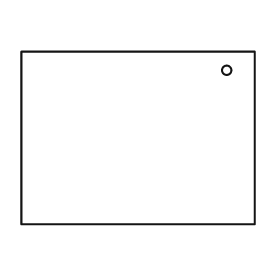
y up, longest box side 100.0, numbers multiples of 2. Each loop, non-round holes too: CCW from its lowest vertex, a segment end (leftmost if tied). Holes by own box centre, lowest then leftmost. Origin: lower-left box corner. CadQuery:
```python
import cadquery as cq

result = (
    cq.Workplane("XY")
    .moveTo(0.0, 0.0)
    .lineTo(100.0, 0.0)
    .lineTo(100.0, 74.0)
    .lineTo(0.0, 74.0)
    .close()
    .moveTo(88.0, 66.0)
    .circle(2.0)
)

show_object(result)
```